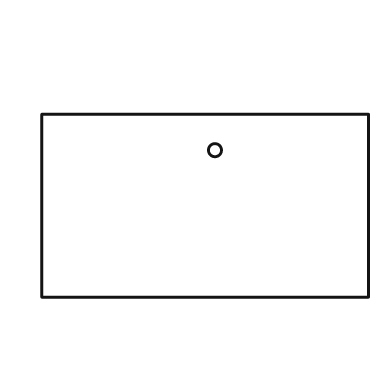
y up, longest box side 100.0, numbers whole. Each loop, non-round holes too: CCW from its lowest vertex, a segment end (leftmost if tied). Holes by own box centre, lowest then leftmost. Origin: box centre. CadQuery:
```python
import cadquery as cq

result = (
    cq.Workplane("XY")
    .moveTo(-50.0, -28.0)
    .lineTo(50.0, -28.0)
    .lineTo(50.0, 28.0)
    .lineTo(-50.0, 28.0)
    .close()
    .moveTo(3.0, 17.0)
    .circle(2.0)
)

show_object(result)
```